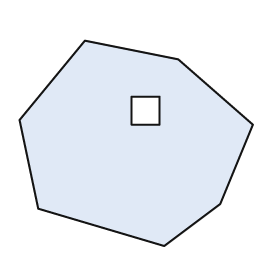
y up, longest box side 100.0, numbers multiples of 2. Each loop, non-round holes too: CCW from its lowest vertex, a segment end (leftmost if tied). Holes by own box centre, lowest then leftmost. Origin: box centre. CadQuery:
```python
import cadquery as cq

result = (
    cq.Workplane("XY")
    .moveTo(12.0, -44.0)
    .lineTo(36.0, -26.0)
    .lineTo(50.0, 8.0)
    .lineTo(18.0, 36.0)
    .lineTo(-22.0, 44.0)
    .lineTo(-50.0, 10.0)
    .lineTo(-42.0, -28.0)
    .close()
    .moveTo(-2.0, 8.0)
    .lineTo(10.0, 8.0)
    .lineTo(10.0, 20.0)
    .lineTo(-2.0, 20.0)
    .close()
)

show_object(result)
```